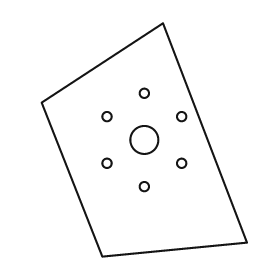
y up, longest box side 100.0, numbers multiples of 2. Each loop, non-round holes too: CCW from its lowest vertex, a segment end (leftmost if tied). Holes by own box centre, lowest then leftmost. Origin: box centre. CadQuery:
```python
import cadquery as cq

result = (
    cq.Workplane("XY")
    .moveTo(-18.0, -50.0)
    .lineTo(44.0, -44.0)
    .lineTo(8.0, 50.0)
    .lineTo(-44.0, 16.0)
    .close()
    .moveTo(0.0, -20.0)
    .circle(2.0)
    .moveTo(-16.0, -10.0)
    .circle(2.0)
    .moveTo(16.0, -10.0)
    .circle(2.0)
    .moveTo(0.0, 0.0)
    .circle(6.0)
    .moveTo(-16.0, 10.0)
    .circle(2.0)
    .moveTo(16.0, 10.0)
    .circle(2.0)
    .moveTo(0.0, 20.0)
    .circle(2.0)
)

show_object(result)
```